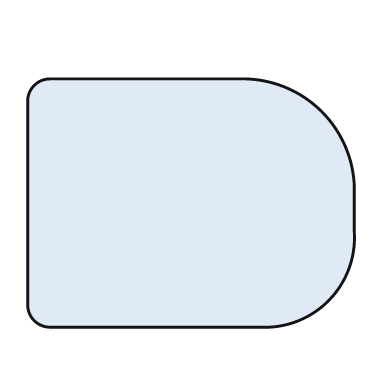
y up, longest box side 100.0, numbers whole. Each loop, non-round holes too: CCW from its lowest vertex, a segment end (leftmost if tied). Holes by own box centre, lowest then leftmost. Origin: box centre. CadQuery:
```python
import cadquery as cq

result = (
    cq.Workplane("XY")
    .moveTo(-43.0, -38.0)
    .lineTo(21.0, -38.0)
    .threePointArc((42.0, -30.0), (50.0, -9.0))
    .lineTo(50.0, 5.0)
    .threePointArc((40.0, 28.0), (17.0, 38.0))
    .lineTo(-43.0, 38.0)
    .threePointArc((-48.0, 36.0), (-50.0, 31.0))
    .lineTo(-50.0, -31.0)
    .threePointArc((-48.0, -36.0), (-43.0, -38.0))
    .close()
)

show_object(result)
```